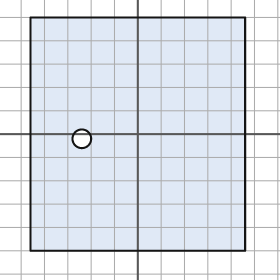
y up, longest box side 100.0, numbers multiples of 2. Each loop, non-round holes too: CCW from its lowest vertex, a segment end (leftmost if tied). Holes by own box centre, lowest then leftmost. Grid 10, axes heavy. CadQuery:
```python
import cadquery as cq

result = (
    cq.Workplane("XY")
    .moveTo(-46.0, -50.0)
    .lineTo(46.0, -50.0)
    .lineTo(46.0, 50.0)
    .lineTo(-46.0, 50.0)
    .close()
    .moveTo(-24.0, -2.0)
    .circle(4.0)
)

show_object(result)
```